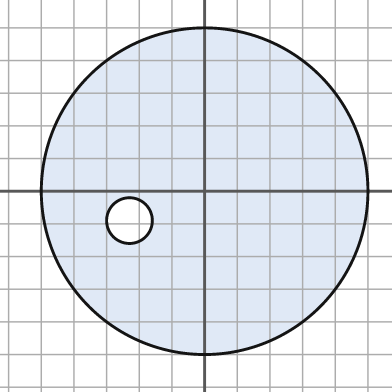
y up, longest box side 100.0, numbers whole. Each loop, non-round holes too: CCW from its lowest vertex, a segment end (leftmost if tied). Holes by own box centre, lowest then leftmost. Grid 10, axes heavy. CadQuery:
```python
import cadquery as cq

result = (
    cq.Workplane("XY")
    .moveTo(0.0, 0.0)
    .circle(50.0)
    .moveTo(-23.0, -9.0)
    .circle(7.0)
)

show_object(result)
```